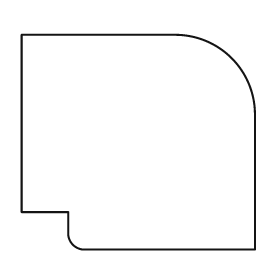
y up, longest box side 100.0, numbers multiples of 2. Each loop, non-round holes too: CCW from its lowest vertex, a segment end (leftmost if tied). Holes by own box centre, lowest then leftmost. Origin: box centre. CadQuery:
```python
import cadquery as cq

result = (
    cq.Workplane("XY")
    .moveTo(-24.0, -46.0)
    .lineTo(50.0, -46.0)
    .lineTo(50.0, 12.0)
    .threePointArc((40.0, 36.0), (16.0, 46.0))
    .lineTo(-50.0, 46.0)
    .lineTo(-50.0, -30.0)
    .lineTo(-30.0, -30.0)
    .lineTo(-30.0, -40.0)
    .threePointArc((-28.0, -44.0), (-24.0, -46.0))
    .close()
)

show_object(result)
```